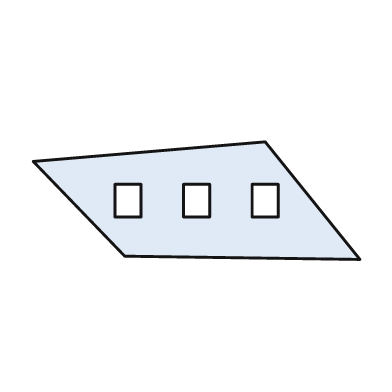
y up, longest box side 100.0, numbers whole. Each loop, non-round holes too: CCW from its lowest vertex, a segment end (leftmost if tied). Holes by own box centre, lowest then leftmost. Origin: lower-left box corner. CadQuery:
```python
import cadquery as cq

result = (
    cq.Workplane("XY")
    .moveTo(100.0, 0.0)
    .lineTo(71.0, 36.0)
    .lineTo(0.0, 30.0)
    .lineTo(28.0, 1.0)
    .close()
    .moveTo(25.0, 13.0)
    .lineTo(33.0, 13.0)
    .lineTo(33.0, 23.0)
    .lineTo(25.0, 23.0)
    .close()
    .moveTo(46.0, 13.0)
    .lineTo(54.0, 13.0)
    .lineTo(54.0, 23.0)
    .lineTo(46.0, 23.0)
    .close()
    .moveTo(67.0, 13.0)
    .lineTo(75.0, 13.0)
    .lineTo(75.0, 23.0)
    .lineTo(67.0, 23.0)
    .close()
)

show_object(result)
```